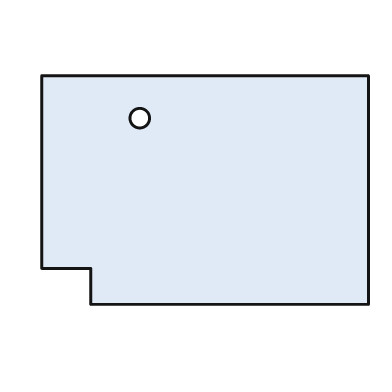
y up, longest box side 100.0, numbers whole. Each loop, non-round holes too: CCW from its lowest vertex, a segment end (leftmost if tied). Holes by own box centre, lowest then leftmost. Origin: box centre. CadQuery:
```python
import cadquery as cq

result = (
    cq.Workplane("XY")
    .moveTo(-35.0, -35.0)
    .lineTo(50.0, -35.0)
    .lineTo(50.0, 35.0)
    .lineTo(-50.0, 35.0)
    .lineTo(-50.0, -24.0)
    .lineTo(-35.0, -24.0)
    .close()
    .moveTo(-20.0, 22.0)
    .circle(3.0)
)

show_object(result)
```